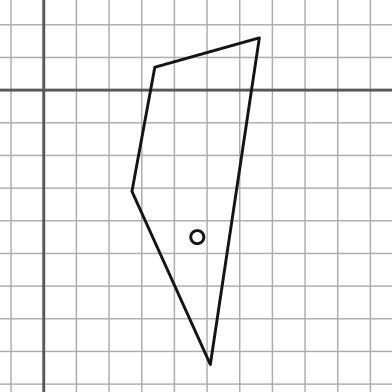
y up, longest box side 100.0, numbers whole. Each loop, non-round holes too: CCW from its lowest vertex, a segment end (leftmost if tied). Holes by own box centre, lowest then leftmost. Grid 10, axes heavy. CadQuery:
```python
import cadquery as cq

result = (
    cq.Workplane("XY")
    .moveTo(51.0, -84.0)
    .lineTo(66.0, 16.0)
    .lineTo(34.0, 7.0)
    .lineTo(27.0, -31.0)
    .close()
    .moveTo(47.0, -45.0)
    .circle(2.0)
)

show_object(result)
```